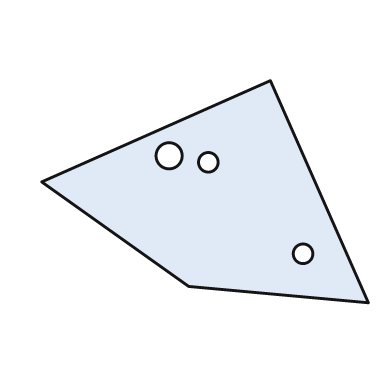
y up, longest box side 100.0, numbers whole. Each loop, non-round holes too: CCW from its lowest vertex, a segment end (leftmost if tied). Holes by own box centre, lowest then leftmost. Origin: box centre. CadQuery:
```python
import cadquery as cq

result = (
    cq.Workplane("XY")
    .moveTo(50.0, -34.0)
    .lineTo(20.0, 34.0)
    .lineTo(-50.0, 3.0)
    .lineTo(-5.0, -29.0)
    .close()
    .moveTo(30.0, -19.0)
    .circle(3.0)
    .moveTo(1.0, 9.0)
    .circle(3.0)
    .moveTo(-11.0, 11.0)
    .circle(4.0)
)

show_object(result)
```